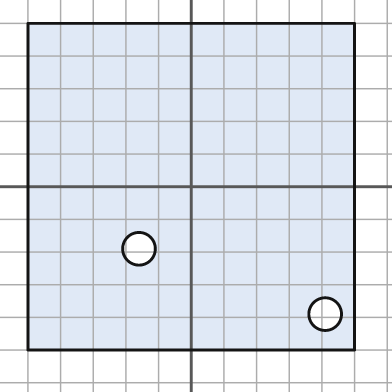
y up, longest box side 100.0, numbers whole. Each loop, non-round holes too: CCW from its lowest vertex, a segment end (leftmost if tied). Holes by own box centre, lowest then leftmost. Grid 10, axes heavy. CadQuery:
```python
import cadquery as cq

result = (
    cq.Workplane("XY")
    .moveTo(-50.0, -50.0)
    .lineTo(50.0, -50.0)
    .lineTo(50.0, 50.0)
    .lineTo(-50.0, 50.0)
    .close()
    .moveTo(41.0, -39.0)
    .circle(5.0)
    .moveTo(-16.0, -19.0)
    .circle(5.0)
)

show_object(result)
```